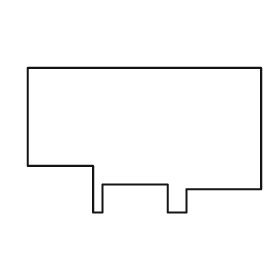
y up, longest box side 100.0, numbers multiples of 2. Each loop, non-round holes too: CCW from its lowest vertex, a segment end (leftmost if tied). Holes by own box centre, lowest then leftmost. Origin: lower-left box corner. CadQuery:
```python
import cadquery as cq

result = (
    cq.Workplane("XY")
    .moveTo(28.0, 0.0)
    .lineTo(32.0, 0.0)
    .lineTo(32.0, 12.0)
    .lineTo(60.0, 12.0)
    .lineTo(60.0, 0.0)
    .lineTo(68.0, 0.0)
    .lineTo(68.0, 10.0)
    .lineTo(100.0, 10.0)
    .lineTo(100.0, 62.0)
    .lineTo(0.0, 62.0)
    .lineTo(0.0, 20.0)
    .lineTo(28.0, 20.0)
    .close()
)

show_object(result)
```